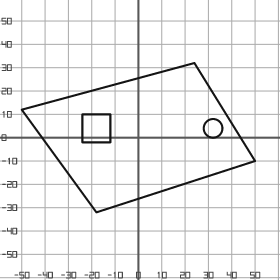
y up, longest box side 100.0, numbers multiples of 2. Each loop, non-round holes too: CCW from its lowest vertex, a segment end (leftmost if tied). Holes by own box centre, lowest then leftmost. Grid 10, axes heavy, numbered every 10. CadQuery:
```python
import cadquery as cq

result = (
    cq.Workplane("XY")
    .moveTo(-18.0, -32.0)
    .lineTo(50.0, -10.0)
    .lineTo(24.0, 32.0)
    .lineTo(-50.0, 12.0)
    .close()
    .moveTo(-24.0, -2.0)
    .lineTo(-12.0, -2.0)
    .lineTo(-12.0, 10.0)
    .lineTo(-24.0, 10.0)
    .close()
    .moveTo(32.0, 4.0)
    .circle(4.0)
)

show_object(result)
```